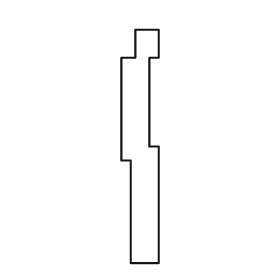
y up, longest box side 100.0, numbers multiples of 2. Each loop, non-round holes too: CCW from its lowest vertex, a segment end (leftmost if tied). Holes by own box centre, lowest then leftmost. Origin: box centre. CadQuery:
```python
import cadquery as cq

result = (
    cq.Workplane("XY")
    .moveTo(-4.0, -50.0)
    .lineTo(8.0, -50.0)
    .lineTo(8.0, 0.0)
    .lineTo(4.0, 0.0)
    .lineTo(4.0, 38.0)
    .lineTo(8.0, 38.0)
    .lineTo(8.0, 50.0)
    .lineTo(-2.0, 50.0)
    .lineTo(-2.0, 38.0)
    .lineTo(-8.0, 38.0)
    .lineTo(-8.0, -6.0)
    .lineTo(-4.0, -6.0)
    .close()
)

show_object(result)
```